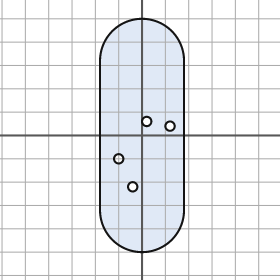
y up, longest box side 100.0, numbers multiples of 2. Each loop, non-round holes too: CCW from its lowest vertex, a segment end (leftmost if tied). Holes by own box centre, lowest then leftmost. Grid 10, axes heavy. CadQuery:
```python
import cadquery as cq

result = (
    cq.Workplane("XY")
    .moveTo(-18.0, -32.0)
    .threePointArc((0.0, -50.0), (18.0, -32.0))
    .lineTo(18.0, 32.0)
    .threePointArc((0.0, 50.0), (-18.0, 32.0))
    .close()
    .moveTo(-4.0, -22.0)
    .circle(2.0)
    .moveTo(-10.0, -10.0)
    .circle(2.0)
    .moveTo(12.0, 4.0)
    .circle(2.0)
    .moveTo(2.0, 6.0)
    .circle(2.0)
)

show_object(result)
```